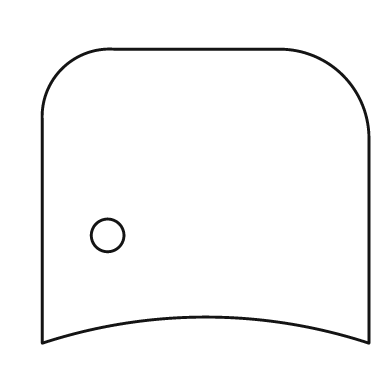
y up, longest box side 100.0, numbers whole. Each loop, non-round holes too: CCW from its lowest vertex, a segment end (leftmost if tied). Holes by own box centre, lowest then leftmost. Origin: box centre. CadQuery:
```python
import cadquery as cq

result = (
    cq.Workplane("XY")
    .moveTo(-50.0, -45.0)
    .threePointArc((0.0, -37.0), (50.0, -45.0))
    .lineTo(50.0, 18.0)
    .threePointArc((42.0, 37.0), (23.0, 45.0))
    .lineTo(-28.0, 45.0)
    .threePointArc((-44.0, 39.0), (-50.0, 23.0))
    .close()
    .moveTo(-30.0, -12.0)
    .circle(5.0)
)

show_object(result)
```